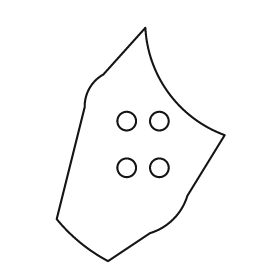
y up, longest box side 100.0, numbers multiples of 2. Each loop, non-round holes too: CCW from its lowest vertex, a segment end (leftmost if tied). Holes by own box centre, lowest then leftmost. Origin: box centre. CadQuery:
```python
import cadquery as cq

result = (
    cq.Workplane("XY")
    .moveTo(-14.0, -50.0)
    .lineTo(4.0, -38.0)
    .threePointArc((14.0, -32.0), (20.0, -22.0))
    .lineTo(36.0, 4.0)
    .threePointArc((12.0, 22.0), (2.0, 50.0))
    .lineTo(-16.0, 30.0)
    .threePointArc((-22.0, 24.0), (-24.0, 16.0))
    .lineTo(-36.0, -32.0)
    .threePointArc((-26.0, -42.0), (-14.0, -50.0))
    .close()
    .moveTo(-6.0, -10.0)
    .circle(4.0)
    .moveTo(8.0, -10.0)
    .circle(4.0)
    .moveTo(-6.0, 10.0)
    .circle(4.0)
    .moveTo(8.0, 10.0)
    .circle(4.0)
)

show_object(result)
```